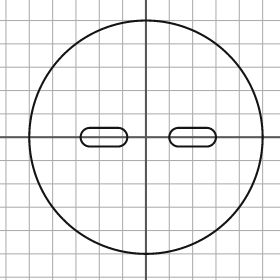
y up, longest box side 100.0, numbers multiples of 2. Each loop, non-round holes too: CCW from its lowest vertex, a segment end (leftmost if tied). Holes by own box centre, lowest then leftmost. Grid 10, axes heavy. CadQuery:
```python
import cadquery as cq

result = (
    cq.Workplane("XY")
    .moveTo(0.0, 0.0)
    .circle(50.0)
    .moveTo(-24.0, -4.0)
    .lineTo(-12.0, -4.0)
    .threePointArc((-8.0, 0.0), (-12.0, 4.0))
    .lineTo(-24.0, 4.0)
    .threePointArc((-28.0, 0.0), (-24.0, -4.0))
    .close()
    .moveTo(14.0, -4.0)
    .lineTo(26.0, -4.0)
    .threePointArc((30.0, 0.0), (26.0, 4.0))
    .lineTo(14.0, 4.0)
    .threePointArc((10.0, 0.0), (14.0, -4.0))
    .close()
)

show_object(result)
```